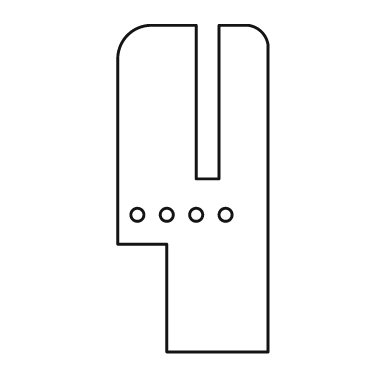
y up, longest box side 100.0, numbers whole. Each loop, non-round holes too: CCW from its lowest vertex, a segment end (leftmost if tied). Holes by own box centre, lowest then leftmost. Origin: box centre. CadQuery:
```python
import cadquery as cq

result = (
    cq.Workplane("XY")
    .moveTo(-8.0, -50.0)
    .lineTo(23.0, -50.0)
    .lineTo(23.0, 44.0)
    .threePointArc((21.0, 48.0), (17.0, 50.0))
    .lineTo(8.0, 50.0)
    .lineTo(8.0, 3.0)
    .lineTo(1.0, 3.0)
    .lineTo(1.0, 50.0)
    .lineTo(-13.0, 50.0)
    .threePointArc((-20.0, 47.0), (-23.0, 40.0))
    .lineTo(-23.0, -17.0)
    .lineTo(-8.0, -17.0)
    .close()
    .moveTo(-17.0, -8.0)
    .circle(2.0)
    .moveTo(-8.0, -8.0)
    .circle(2.0)
    .moveTo(1.0, -8.0)
    .circle(2.0)
    .moveTo(10.0, -8.0)
    .circle(2.0)
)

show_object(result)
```